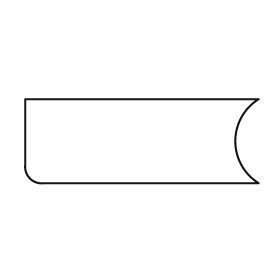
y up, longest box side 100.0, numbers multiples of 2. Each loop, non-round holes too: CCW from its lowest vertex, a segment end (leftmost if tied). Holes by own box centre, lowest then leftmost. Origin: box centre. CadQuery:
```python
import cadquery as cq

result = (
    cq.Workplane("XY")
    .moveTo(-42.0, -18.0)
    .lineTo(50.0, -18.0)
    .threePointArc((40.0, 0.0), (50.0, 18.0))
    .lineTo(-50.0, 18.0)
    .lineTo(-50.0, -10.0)
    .threePointArc((-48.0, -16.0), (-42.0, -18.0))
    .close()
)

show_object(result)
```